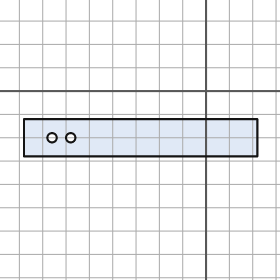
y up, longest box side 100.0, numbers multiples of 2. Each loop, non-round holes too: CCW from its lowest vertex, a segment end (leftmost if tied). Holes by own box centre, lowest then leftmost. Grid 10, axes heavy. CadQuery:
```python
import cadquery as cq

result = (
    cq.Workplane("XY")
    .moveTo(-78.0, -28.0)
    .lineTo(22.0, -28.0)
    .lineTo(22.0, -12.0)
    .lineTo(-78.0, -12.0)
    .close()
    .moveTo(-66.0, -20.0)
    .circle(2.0)
    .moveTo(-58.0, -20.0)
    .circle(2.0)
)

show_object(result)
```